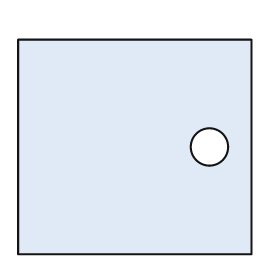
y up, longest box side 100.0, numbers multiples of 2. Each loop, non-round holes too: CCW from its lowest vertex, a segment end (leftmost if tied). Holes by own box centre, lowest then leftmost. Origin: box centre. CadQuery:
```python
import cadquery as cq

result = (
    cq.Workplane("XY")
    .moveTo(-50.0, -46.0)
    .lineTo(50.0, -46.0)
    .lineTo(50.0, 46.0)
    .lineTo(-50.0, 46.0)
    .close()
    .moveTo(32.0, 0.0)
    .circle(8.0)
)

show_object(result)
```